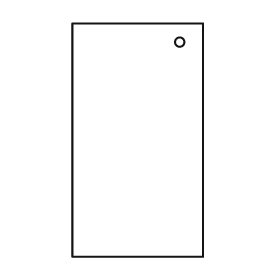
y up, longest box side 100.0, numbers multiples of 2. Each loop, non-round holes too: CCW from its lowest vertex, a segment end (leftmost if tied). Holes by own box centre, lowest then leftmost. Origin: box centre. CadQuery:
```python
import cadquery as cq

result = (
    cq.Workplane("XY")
    .moveTo(-28.0, -50.0)
    .lineTo(28.0, -50.0)
    .lineTo(28.0, 50.0)
    .lineTo(-28.0, 50.0)
    .close()
    .moveTo(18.0, 42.0)
    .circle(2.0)
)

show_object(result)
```